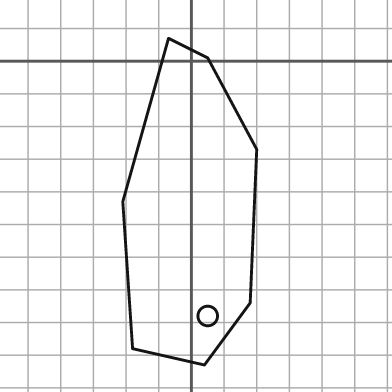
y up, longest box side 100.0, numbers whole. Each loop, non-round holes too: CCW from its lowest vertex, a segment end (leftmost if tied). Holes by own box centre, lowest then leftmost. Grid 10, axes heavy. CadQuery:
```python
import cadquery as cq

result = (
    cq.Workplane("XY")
    .moveTo(4.0, -93.0)
    .lineTo(18.0, -74.0)
    .lineTo(20.0, -27.0)
    .lineTo(5.0, 1.0)
    .lineTo(-7.0, 7.0)
    .lineTo(-21.0, -43.0)
    .lineTo(-18.0, -88.0)
    .close()
    .moveTo(5.0, -78.0)
    .circle(3.0)
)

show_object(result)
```